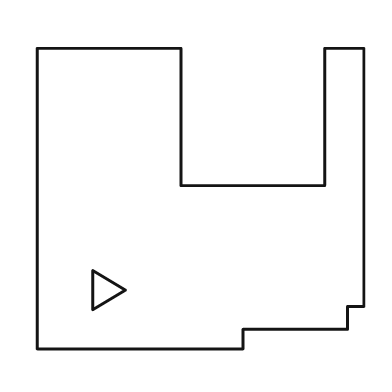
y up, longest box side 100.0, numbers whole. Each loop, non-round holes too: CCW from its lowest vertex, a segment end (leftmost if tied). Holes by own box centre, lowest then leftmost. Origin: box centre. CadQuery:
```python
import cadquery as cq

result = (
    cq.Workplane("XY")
    .moveTo(-50.0, -46.0)
    .lineTo(13.0, -46.0)
    .lineTo(13.0, -40.0)
    .lineTo(45.0, -40.0)
    .lineTo(45.0, -33.0)
    .lineTo(50.0, -33.0)
    .lineTo(50.0, 46.0)
    .lineTo(38.0, 46.0)
    .lineTo(38.0, 4.0)
    .lineTo(-6.0, 4.0)
    .lineTo(-6.0, 46.0)
    .lineTo(-50.0, 46.0)
    .close()
    .moveTo(-33.0, -34.0)
    .lineTo(-23.0, -28.0)
    .lineTo(-33.0, -22.0)
    .close()
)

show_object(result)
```